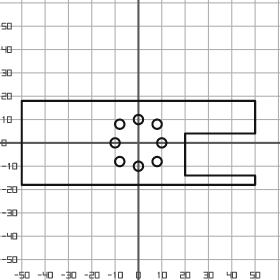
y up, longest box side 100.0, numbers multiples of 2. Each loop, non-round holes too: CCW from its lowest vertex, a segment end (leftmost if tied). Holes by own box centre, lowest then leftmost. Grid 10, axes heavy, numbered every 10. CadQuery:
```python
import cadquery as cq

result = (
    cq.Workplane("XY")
    .moveTo(-50.0, -18.0)
    .lineTo(50.0, -18.0)
    .lineTo(50.0, -14.0)
    .lineTo(20.0, -14.0)
    .lineTo(20.0, 4.0)
    .lineTo(50.0, 4.0)
    .lineTo(50.0, 18.0)
    .lineTo(-50.0, 18.0)
    .close()
    .moveTo(0.0, -10.0)
    .circle(2.0)
    .moveTo(-8.0, -8.0)
    .circle(2.0)
    .moveTo(8.0, -8.0)
    .circle(2.0)
    .moveTo(-10.0, 0.0)
    .circle(2.0)
    .moveTo(10.0, 0.0)
    .circle(2.0)
    .moveTo(-8.0, 8.0)
    .circle(2.0)
    .moveTo(8.0, 8.0)
    .circle(2.0)
    .moveTo(0.0, 10.0)
    .circle(2.0)
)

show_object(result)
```